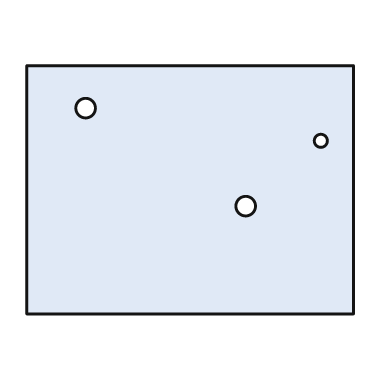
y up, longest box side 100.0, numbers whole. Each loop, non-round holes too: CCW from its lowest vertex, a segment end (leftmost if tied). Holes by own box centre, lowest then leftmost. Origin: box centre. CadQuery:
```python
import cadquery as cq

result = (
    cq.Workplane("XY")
    .moveTo(-50.0, -38.0)
    .lineTo(50.0, -38.0)
    .lineTo(50.0, 38.0)
    .lineTo(-50.0, 38.0)
    .close()
    .moveTo(17.0, -5.0)
    .circle(3.0)
    .moveTo(40.0, 15.0)
    .circle(2.0)
    .moveTo(-32.0, 25.0)
    .circle(3.0)
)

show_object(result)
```